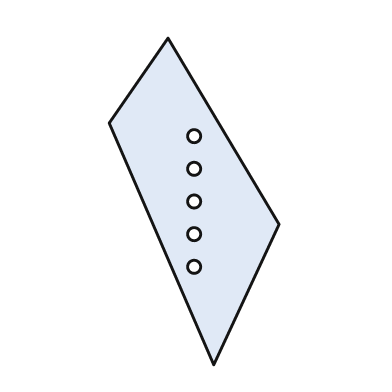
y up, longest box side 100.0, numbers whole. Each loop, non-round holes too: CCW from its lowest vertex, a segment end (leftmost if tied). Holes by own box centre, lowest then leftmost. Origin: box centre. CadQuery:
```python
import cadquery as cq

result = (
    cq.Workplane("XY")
    .moveTo(6.0, -50.0)
    .lineTo(26.0, -7.0)
    .lineTo(-8.0, 50.0)
    .lineTo(-26.0, 24.0)
    .close()
    .moveTo(0.0, -20.0)
    .circle(2.0)
    .moveTo(0.0, -10.0)
    .circle(2.0)
    .moveTo(0.0, 0.0)
    .circle(2.0)
    .moveTo(0.0, 10.0)
    .circle(2.0)
    .moveTo(0.0, 20.0)
    .circle(2.0)
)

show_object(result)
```